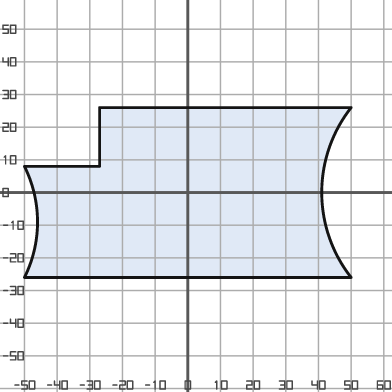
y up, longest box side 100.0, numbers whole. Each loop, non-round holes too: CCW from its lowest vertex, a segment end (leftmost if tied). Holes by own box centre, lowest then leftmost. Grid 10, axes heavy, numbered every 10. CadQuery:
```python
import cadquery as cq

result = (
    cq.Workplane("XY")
    .moveTo(-50.0, -26.0)
    .lineTo(50.0, -26.0)
    .threePointArc((41.0, 0.0), (50.0, 26.0))
    .lineTo(-27.0, 26.0)
    .lineTo(-27.0, 8.0)
    .lineTo(-50.0, 8.0)
    .threePointArc((-46.0, -9.0), (-50.0, -26.0))
    .close()
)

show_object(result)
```